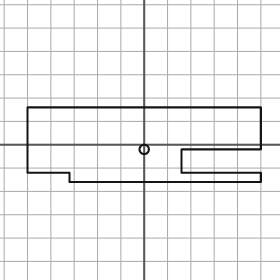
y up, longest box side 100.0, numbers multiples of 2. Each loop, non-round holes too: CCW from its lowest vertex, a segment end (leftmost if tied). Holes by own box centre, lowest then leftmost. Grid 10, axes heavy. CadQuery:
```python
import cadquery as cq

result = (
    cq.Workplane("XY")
    .moveTo(-32.0, -16.0)
    .lineTo(50.0, -16.0)
    .lineTo(50.0, -12.0)
    .lineTo(16.0, -12.0)
    .lineTo(16.0, -2.0)
    .lineTo(50.0, -2.0)
    .lineTo(50.0, 16.0)
    .lineTo(-50.0, 16.0)
    .lineTo(-50.0, -12.0)
    .lineTo(-32.0, -12.0)
    .close()
    .moveTo(0.0, -2.0)
    .circle(2.0)
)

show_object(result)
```